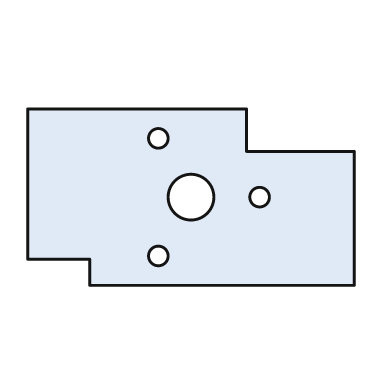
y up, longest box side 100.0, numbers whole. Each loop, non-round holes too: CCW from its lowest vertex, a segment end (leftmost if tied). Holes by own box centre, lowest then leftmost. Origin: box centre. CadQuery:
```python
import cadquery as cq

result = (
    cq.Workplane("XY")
    .moveTo(-31.0, -27.0)
    .lineTo(50.0, -27.0)
    .lineTo(50.0, 14.0)
    .lineTo(17.0, 14.0)
    .lineTo(17.0, 27.0)
    .lineTo(-50.0, 27.0)
    .lineTo(-50.0, -19.0)
    .lineTo(-31.0, -19.0)
    .close()
    .moveTo(-10.0, -18.0)
    .circle(3.0)
    .moveTo(0.0, 0.0)
    .circle(7.0)
    .moveTo(21.0, 0.0)
    .circle(3.0)
    .moveTo(-10.0, 18.0)
    .circle(3.0)
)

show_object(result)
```